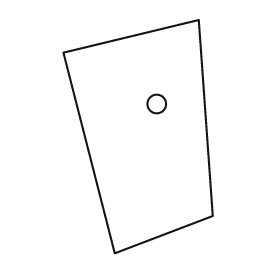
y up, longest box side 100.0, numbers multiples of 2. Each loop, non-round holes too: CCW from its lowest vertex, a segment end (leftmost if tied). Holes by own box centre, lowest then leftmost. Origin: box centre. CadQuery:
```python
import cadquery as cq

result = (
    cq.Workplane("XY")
    .moveTo(-10.0, -50.0)
    .lineTo(32.0, -34.0)
    .lineTo(26.0, 50.0)
    .lineTo(-32.0, 36.0)
    .close()
    .moveTo(8.0, 14.0)
    .circle(4.0)
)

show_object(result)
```